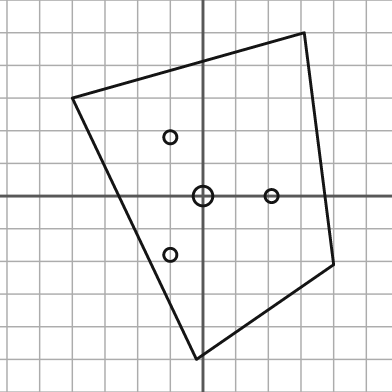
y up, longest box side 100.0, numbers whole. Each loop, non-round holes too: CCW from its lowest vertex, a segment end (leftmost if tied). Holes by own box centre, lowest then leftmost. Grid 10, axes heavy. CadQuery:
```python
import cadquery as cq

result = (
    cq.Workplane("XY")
    .moveTo(-2.0, -50.0)
    .lineTo(40.0, -21.0)
    .lineTo(31.0, 50.0)
    .lineTo(-40.0, 30.0)
    .close()
    .moveTo(-10.0, -18.0)
    .circle(2.0)
    .moveTo(0.0, 0.0)
    .circle(3.0)
    .moveTo(21.0, 0.0)
    .circle(2.0)
    .moveTo(-10.0, 18.0)
    .circle(2.0)
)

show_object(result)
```